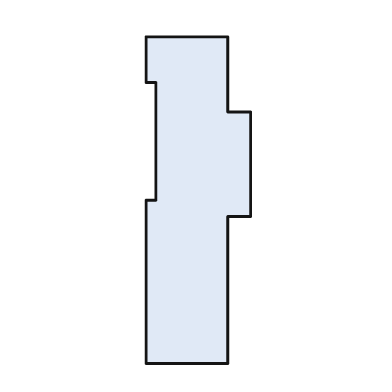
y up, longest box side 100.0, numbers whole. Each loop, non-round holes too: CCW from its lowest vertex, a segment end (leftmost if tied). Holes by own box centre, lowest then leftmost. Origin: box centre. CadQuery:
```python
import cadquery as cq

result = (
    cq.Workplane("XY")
    .moveTo(-16.0, -50.0)
    .lineTo(9.0, -50.0)
    .lineTo(9.0, -5.0)
    .lineTo(16.0, -5.0)
    .lineTo(16.0, 27.0)
    .lineTo(9.0, 27.0)
    .lineTo(9.0, 50.0)
    .lineTo(-16.0, 50.0)
    .lineTo(-16.0, 36.0)
    .lineTo(-13.0, 36.0)
    .lineTo(-13.0, 0.0)
    .lineTo(-16.0, 0.0)
    .close()
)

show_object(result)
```